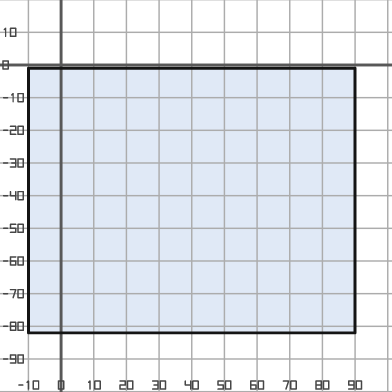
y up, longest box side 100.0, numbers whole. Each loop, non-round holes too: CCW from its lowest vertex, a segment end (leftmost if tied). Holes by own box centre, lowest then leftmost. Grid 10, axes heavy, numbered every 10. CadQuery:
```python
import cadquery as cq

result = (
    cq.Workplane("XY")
    .moveTo(-10.0, -82.0)
    .lineTo(90.0, -82.0)
    .lineTo(90.0, -1.0)
    .lineTo(-10.0, -1.0)
    .close()
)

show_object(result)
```